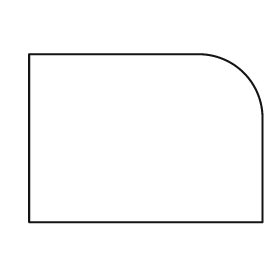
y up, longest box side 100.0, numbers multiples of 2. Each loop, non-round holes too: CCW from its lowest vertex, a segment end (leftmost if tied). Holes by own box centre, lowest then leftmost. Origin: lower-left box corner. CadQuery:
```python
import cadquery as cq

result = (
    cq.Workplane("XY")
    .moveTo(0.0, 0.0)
    .lineTo(100.0, 0.0)
    .lineTo(100.0, 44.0)
    .threePointArc((92.0, 64.0), (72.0, 72.0))
    .lineTo(0.0, 72.0)
    .close()
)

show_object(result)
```